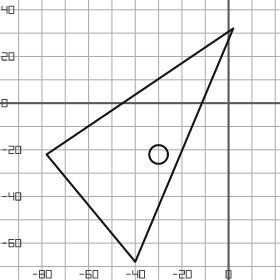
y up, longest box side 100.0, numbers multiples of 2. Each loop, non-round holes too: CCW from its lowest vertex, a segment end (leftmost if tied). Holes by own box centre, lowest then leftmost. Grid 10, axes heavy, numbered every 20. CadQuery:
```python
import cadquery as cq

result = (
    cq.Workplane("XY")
    .moveTo(-40.0, -68.0)
    .lineTo(2.0, 32.0)
    .lineTo(-78.0, -22.0)
    .close()
    .moveTo(-30.0, -22.0)
    .circle(4.0)
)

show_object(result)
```